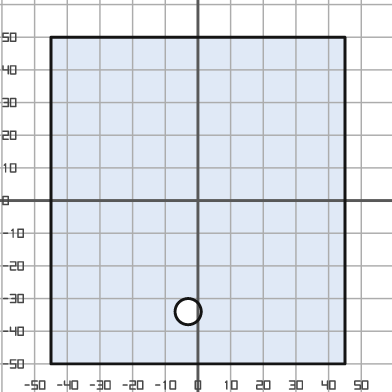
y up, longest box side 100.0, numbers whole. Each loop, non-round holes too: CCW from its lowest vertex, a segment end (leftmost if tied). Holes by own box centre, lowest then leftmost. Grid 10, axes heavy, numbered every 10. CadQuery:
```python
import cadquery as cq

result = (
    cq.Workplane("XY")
    .moveTo(-45.0, -50.0)
    .lineTo(45.0, -50.0)
    .lineTo(45.0, 50.0)
    .lineTo(-45.0, 50.0)
    .close()
    .moveTo(-3.0, -34.0)
    .circle(4.0)
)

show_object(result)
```